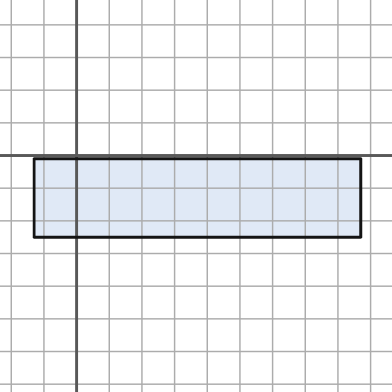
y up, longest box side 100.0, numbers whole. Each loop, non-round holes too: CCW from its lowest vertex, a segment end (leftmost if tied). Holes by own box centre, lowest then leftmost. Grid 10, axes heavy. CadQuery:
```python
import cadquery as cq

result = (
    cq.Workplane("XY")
    .moveTo(-13.0, -25.0)
    .lineTo(87.0, -25.0)
    .lineTo(87.0, -1.0)
    .lineTo(-13.0, -1.0)
    .close()
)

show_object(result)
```